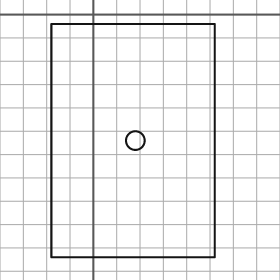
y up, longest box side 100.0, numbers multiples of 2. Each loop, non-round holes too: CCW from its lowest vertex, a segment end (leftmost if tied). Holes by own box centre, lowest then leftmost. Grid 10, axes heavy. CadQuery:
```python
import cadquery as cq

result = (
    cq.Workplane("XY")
    .moveTo(-18.0, -104.0)
    .lineTo(52.0, -104.0)
    .lineTo(52.0, -4.0)
    .lineTo(-18.0, -4.0)
    .close()
    .moveTo(18.0, -54.0)
    .circle(4.0)
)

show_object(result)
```